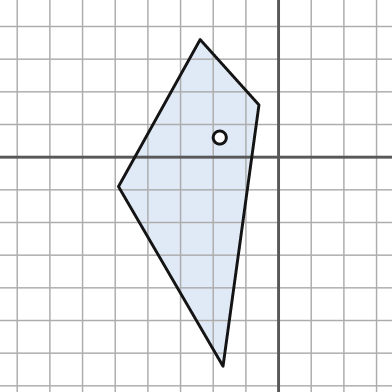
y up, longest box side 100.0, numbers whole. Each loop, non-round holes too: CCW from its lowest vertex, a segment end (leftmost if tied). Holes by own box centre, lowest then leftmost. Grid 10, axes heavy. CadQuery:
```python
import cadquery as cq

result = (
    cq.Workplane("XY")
    .moveTo(-17.0, -64.0)
    .lineTo(-6.0, 16.0)
    .lineTo(-24.0, 36.0)
    .lineTo(-49.0, -9.0)
    .close()
    .moveTo(-18.0, 6.0)
    .circle(2.0)
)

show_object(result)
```